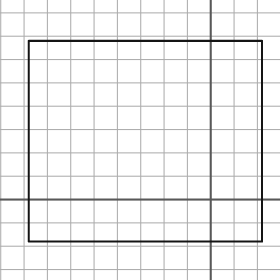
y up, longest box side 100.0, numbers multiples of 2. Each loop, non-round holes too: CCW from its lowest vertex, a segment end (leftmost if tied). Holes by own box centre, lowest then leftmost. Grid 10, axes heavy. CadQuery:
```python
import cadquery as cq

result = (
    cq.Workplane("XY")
    .moveTo(-78.0, -18.0)
    .lineTo(22.0, -18.0)
    .lineTo(22.0, 68.0)
    .lineTo(-78.0, 68.0)
    .close()
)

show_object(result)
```